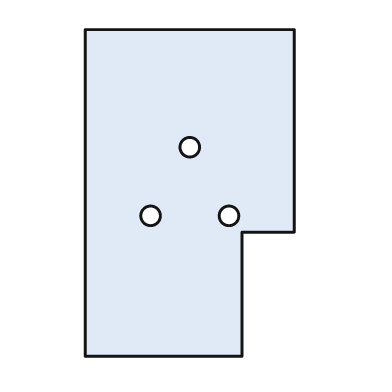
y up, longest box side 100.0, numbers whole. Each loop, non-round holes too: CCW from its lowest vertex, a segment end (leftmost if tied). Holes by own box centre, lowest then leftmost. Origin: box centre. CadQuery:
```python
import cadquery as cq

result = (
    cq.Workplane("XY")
    .moveTo(-32.0, -50.0)
    .lineTo(16.0, -50.0)
    .lineTo(16.0, -12.0)
    .lineTo(32.0, -12.0)
    .lineTo(32.0, 50.0)
    .lineTo(-32.0, 50.0)
    .close()
    .moveTo(-12.0, -7.0)
    .circle(3.0)
    .moveTo(12.0, -7.0)
    .circle(3.0)
    .moveTo(0.0, 14.0)
    .circle(3.0)
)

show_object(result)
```